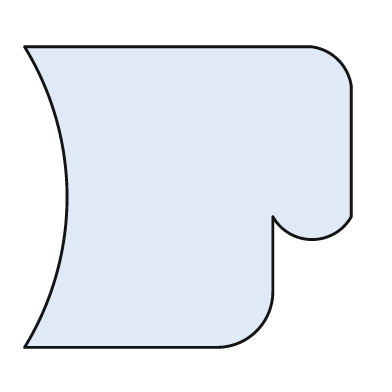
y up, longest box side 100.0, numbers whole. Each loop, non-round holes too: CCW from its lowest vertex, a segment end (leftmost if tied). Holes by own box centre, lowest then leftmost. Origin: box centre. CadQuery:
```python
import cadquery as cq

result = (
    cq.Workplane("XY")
    .moveTo(-50.0, -46.0)
    .lineTo(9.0, -46.0)
    .threePointArc((21.0, -41.0), (26.0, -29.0))
    .lineTo(26.0, -6.0)
    .threePointArc((38.0, -13.0), (50.0, -6.0))
    .lineTo(50.0, 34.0)
    .threePointArc((46.0, 42.0), (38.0, 46.0))
    .lineTo(-50.0, 46.0)
    .threePointArc((-37.0, 0.0), (-50.0, -46.0))
    .close()
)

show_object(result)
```